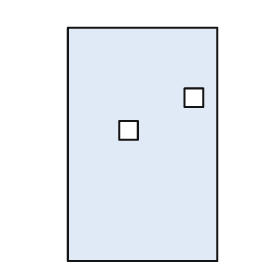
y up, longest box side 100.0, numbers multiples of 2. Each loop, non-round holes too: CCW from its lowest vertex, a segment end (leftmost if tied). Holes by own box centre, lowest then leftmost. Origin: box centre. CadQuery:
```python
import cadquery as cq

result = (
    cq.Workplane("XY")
    .moveTo(-32.0, -50.0)
    .lineTo(32.0, -50.0)
    .lineTo(32.0, 50.0)
    .lineTo(-32.0, 50.0)
    .close()
    .moveTo(-10.0, 2.0)
    .lineTo(-2.0, 2.0)
    .lineTo(-2.0, 10.0)
    .lineTo(-10.0, 10.0)
    .close()
    .moveTo(18.0, 16.0)
    .lineTo(26.0, 16.0)
    .lineTo(26.0, 24.0)
    .lineTo(18.0, 24.0)
    .close()
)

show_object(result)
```